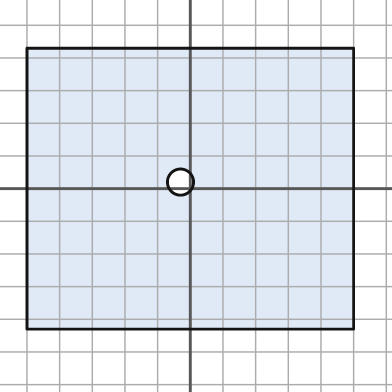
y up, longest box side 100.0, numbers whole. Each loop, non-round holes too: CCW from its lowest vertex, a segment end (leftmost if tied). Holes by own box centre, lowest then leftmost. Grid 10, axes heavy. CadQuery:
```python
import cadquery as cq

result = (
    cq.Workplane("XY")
    .moveTo(-50.0, -43.0)
    .lineTo(50.0, -43.0)
    .lineTo(50.0, 43.0)
    .lineTo(-50.0, 43.0)
    .close()
    .moveTo(-3.0, 2.0)
    .circle(4.0)
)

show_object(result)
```